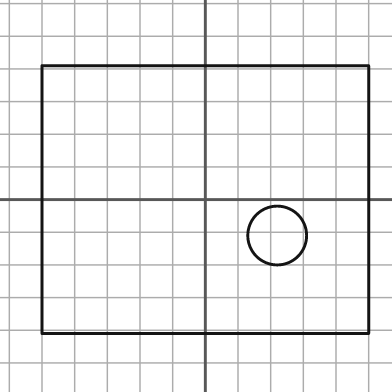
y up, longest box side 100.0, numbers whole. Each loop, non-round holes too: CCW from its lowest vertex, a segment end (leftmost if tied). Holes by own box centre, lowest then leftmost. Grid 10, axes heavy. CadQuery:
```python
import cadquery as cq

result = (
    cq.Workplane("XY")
    .moveTo(-50.0, -41.0)
    .lineTo(50.0, -41.0)
    .lineTo(50.0, 41.0)
    .lineTo(-50.0, 41.0)
    .close()
    .moveTo(22.0, -11.0)
    .circle(9.0)
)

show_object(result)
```